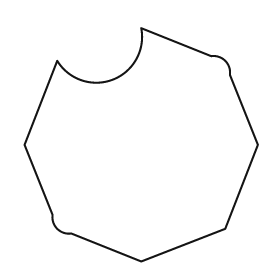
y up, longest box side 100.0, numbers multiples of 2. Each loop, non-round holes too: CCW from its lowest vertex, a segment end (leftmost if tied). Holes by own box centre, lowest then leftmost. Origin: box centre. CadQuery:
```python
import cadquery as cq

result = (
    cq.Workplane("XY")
    .moveTo(0.0, -50.0)
    .lineTo(36.0, -36.0)
    .lineTo(50.0, 0.0)
    .lineTo(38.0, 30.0)
    .threePointArc((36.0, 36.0), (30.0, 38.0))
    .lineTo(0.0, 50.0)
    .threePointArc((-12.0, 28.0), (-36.0, 36.0))
    .lineTo(-50.0, 0.0)
    .lineTo(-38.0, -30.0)
    .threePointArc((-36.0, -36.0), (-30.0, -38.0))
    .close()
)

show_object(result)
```